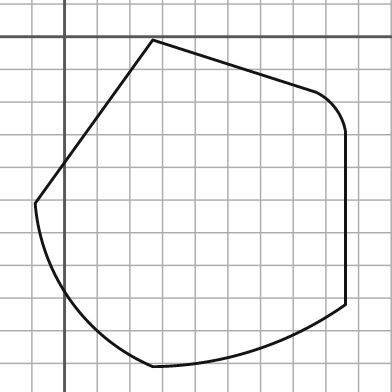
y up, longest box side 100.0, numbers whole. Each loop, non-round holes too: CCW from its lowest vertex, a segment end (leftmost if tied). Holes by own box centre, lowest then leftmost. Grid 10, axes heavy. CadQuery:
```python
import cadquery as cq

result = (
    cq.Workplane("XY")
    .moveTo(27.0, -101.0)
    .threePointArc((58.0, -96.0), (86.0, -82.0))
    .lineTo(86.0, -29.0)
    .threePointArc((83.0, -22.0), (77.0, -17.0))
    .lineTo(27.0, -1.0)
    .lineTo(-9.0, -51.0)
    .threePointArc((2.0, -81.0), (27.0, -101.0))
    .close()
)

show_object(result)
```